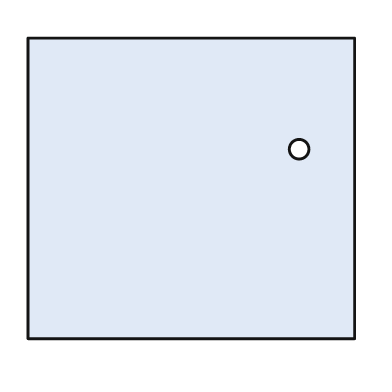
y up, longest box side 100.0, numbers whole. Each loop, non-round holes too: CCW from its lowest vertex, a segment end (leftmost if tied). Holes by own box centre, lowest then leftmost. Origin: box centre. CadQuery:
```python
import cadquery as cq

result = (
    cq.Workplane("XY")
    .moveTo(-50.0, -46.0)
    .lineTo(50.0, -46.0)
    .lineTo(50.0, 46.0)
    .lineTo(-50.0, 46.0)
    .close()
    .moveTo(33.0, 12.0)
    .circle(3.0)
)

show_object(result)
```